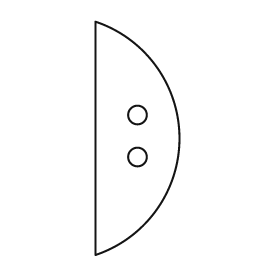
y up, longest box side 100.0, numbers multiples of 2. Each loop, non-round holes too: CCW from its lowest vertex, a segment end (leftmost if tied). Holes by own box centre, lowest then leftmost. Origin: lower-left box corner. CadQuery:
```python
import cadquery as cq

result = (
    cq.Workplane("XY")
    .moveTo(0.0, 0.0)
    .threePointArc((36.0, 50.0), (0.0, 100.0))
    .close()
    .moveTo(18.0, 42.0)
    .circle(4.0)
    .moveTo(18.0, 60.0)
    .circle(4.0)
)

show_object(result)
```